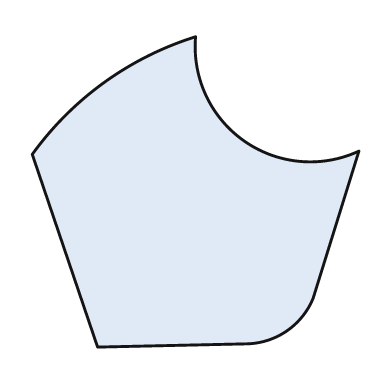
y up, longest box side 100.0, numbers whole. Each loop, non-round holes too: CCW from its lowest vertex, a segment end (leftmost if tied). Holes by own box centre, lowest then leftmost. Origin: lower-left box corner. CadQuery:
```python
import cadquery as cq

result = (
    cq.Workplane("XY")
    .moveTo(20.0, 0.0)
    .lineTo(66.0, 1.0)
    .threePointArc((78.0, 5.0), (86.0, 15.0))
    .lineTo(100.0, 60.0)
    .threePointArc((65.0, 63.0), (50.0, 95.0))
    .threePointArc((22.0, 81.0), (0.0, 59.0))
    .close()
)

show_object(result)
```